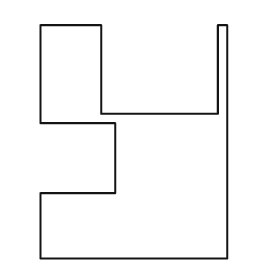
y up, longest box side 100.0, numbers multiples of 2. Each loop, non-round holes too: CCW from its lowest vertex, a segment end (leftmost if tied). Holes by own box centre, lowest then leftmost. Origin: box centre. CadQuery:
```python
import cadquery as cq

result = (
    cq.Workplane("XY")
    .moveTo(-40.0, -50.0)
    .lineTo(40.0, -50.0)
    .lineTo(40.0, 50.0)
    .lineTo(36.0, 50.0)
    .lineTo(36.0, 12.0)
    .lineTo(-14.0, 12.0)
    .lineTo(-14.0, 50.0)
    .lineTo(-40.0, 50.0)
    .lineTo(-40.0, 8.0)
    .lineTo(-8.0, 8.0)
    .lineTo(-8.0, -22.0)
    .lineTo(-40.0, -22.0)
    .close()
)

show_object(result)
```